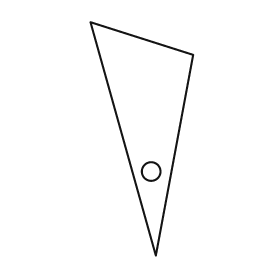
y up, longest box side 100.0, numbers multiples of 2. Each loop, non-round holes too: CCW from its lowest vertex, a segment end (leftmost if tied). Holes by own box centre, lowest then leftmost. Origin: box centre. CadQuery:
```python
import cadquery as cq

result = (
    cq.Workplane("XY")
    .moveTo(6.0, -50.0)
    .lineTo(22.0, 36.0)
    .lineTo(-22.0, 50.0)
    .close()
    .moveTo(4.0, -14.0)
    .circle(4.0)
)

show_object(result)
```